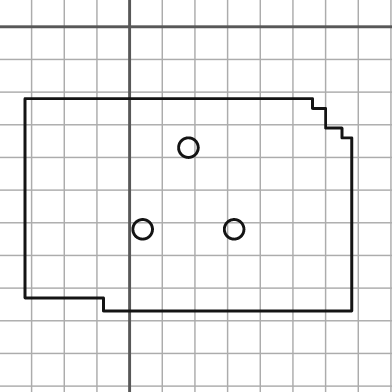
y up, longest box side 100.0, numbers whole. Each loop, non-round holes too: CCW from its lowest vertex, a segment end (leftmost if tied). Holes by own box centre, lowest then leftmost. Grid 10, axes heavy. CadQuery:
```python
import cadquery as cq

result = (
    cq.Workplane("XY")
    .moveTo(-8.0, -87.0)
    .lineTo(68.0, -87.0)
    .lineTo(68.0, -34.0)
    .lineTo(65.0, -34.0)
    .lineTo(65.0, -31.0)
    .lineTo(60.0, -31.0)
    .lineTo(60.0, -25.0)
    .lineTo(56.0, -25.0)
    .lineTo(56.0, -22.0)
    .lineTo(-32.0, -22.0)
    .lineTo(-32.0, -83.0)
    .lineTo(-8.0, -83.0)
    .close()
    .moveTo(4.0, -62.0)
    .circle(3.0)
    .moveTo(32.0, -62.0)
    .circle(3.0)
    .moveTo(18.0, -37.0)
    .circle(3.0)
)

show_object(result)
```